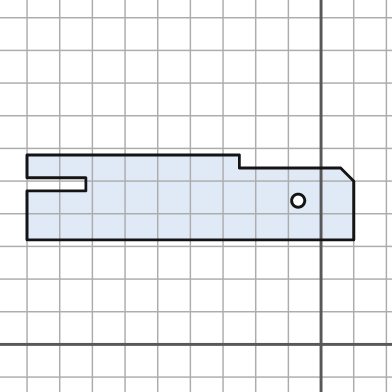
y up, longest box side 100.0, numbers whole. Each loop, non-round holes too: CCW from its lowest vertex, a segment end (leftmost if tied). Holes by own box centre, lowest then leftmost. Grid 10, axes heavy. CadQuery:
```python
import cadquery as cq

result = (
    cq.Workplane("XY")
    .moveTo(-90.0, 32.0)
    .lineTo(10.0, 32.0)
    .lineTo(10.0, 50.0)
    .lineTo(6.0, 54.0)
    .lineTo(-25.0, 54.0)
    .lineTo(-25.0, 58.0)
    .lineTo(-90.0, 58.0)
    .lineTo(-90.0, 51.0)
    .lineTo(-72.0, 51.0)
    .lineTo(-72.0, 47.0)
    .lineTo(-90.0, 47.0)
    .close()
    .moveTo(-7.0, 44.0)
    .circle(2.0)
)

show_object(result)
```